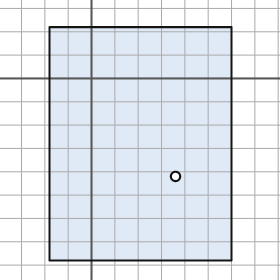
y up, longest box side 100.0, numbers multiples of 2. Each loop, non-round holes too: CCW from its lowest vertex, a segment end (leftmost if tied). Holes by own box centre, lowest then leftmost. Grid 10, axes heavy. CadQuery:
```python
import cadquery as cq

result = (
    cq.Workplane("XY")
    .moveTo(-18.0, -78.0)
    .lineTo(60.0, -78.0)
    .lineTo(60.0, 22.0)
    .lineTo(-18.0, 22.0)
    .close()
    .moveTo(36.0, -42.0)
    .circle(2.0)
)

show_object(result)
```